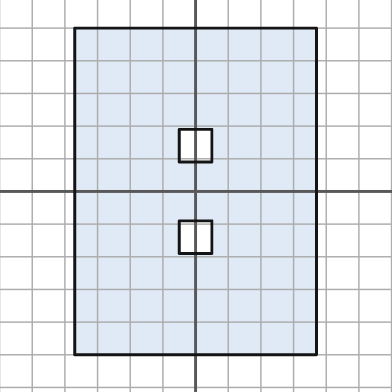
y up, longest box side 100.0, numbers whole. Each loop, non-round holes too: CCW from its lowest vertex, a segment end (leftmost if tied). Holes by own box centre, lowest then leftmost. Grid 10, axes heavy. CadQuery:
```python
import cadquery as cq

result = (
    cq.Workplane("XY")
    .moveTo(-37.0, -50.0)
    .lineTo(37.0, -50.0)
    .lineTo(37.0, 50.0)
    .lineTo(-37.0, 50.0)
    .close()
    .moveTo(-5.0, -19.0)
    .lineTo(5.0, -19.0)
    .lineTo(5.0, -9.0)
    .lineTo(-5.0, -9.0)
    .close()
    .moveTo(-5.0, 9.0)
    .lineTo(5.0, 9.0)
    .lineTo(5.0, 19.0)
    .lineTo(-5.0, 19.0)
    .close()
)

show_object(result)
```